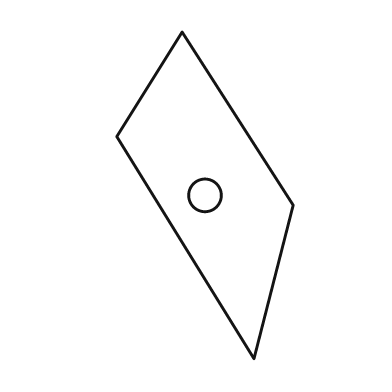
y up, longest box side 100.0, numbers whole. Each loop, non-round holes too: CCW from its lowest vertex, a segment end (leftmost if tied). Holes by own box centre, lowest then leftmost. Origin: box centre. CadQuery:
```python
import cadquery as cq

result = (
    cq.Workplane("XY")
    .moveTo(15.0, -50.0)
    .lineTo(27.0, -3.0)
    .lineTo(-7.0, 50.0)
    .lineTo(-27.0, 18.0)
    .close()
    .moveTo(0.0, 0.0)
    .circle(5.0)
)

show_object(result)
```